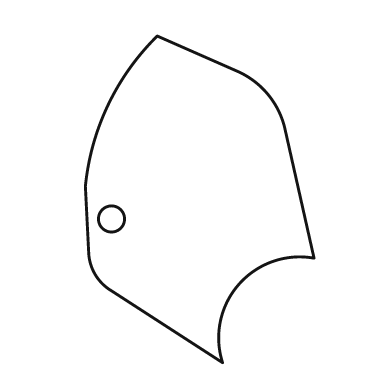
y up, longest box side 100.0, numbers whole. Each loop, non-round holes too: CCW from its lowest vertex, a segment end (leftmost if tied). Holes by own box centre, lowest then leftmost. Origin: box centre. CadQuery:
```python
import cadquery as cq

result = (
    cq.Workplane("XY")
    .moveTo(7.0, -50.0)
    .threePointArc((12.0, -26.0), (35.0, -18.0))
    .lineTo(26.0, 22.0)
    .threePointArc((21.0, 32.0), (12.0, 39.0))
    .lineTo(-13.0, 50.0)
    .threePointArc((-28.0, 29.0), (-35.0, 4.0))
    .lineTo(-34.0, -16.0)
    .threePointArc((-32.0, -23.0), (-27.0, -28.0))
    .close()
    .moveTo(-27.0, -6.0)
    .circle(4.0)
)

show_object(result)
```